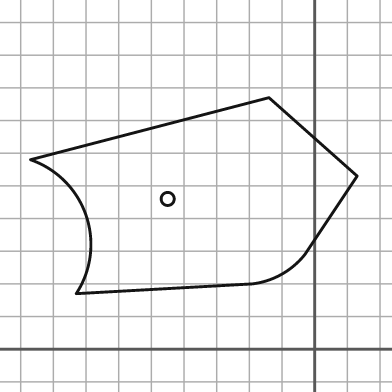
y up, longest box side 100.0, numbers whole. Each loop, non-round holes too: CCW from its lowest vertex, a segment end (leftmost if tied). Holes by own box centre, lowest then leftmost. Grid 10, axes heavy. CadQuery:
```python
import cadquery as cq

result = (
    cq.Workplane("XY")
    .moveTo(-73.0, 17.0)
    .lineTo(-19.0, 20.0)
    .threePointArc((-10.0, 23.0), (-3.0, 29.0))
    .lineTo(13.0, 53.0)
    .lineTo(-14.0, 77.0)
    .lineTo(-87.0, 58.0)
    .threePointArc((-70.0, 41.0), (-73.0, 17.0))
    .close()
    .moveTo(-45.0, 46.0)
    .circle(2.0)
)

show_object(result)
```